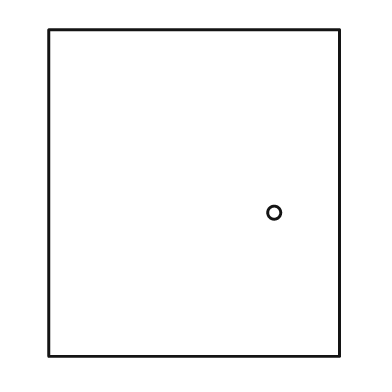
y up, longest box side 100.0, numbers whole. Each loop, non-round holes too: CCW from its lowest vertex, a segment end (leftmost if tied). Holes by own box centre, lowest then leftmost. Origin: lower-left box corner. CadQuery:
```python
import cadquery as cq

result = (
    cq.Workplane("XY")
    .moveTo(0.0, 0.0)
    .lineTo(89.0, 0.0)
    .lineTo(89.0, 100.0)
    .lineTo(0.0, 100.0)
    .close()
    .moveTo(69.0, 44.0)
    .circle(2.0)
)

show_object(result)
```